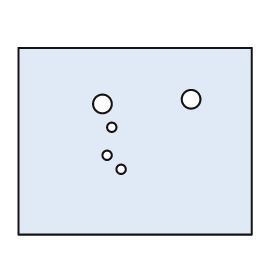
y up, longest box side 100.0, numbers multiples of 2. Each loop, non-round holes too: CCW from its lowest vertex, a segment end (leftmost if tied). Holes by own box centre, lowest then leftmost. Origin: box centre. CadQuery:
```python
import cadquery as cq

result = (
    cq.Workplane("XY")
    .moveTo(-50.0, -40.0)
    .lineTo(50.0, -40.0)
    .lineTo(50.0, 40.0)
    .lineTo(-50.0, 40.0)
    .close()
    .moveTo(-6.0, -12.0)
    .circle(2.0)
    .moveTo(-12.0, -6.0)
    .circle(2.0)
    .moveTo(-10.0, 6.0)
    .circle(2.0)
    .moveTo(-14.0, 16.0)
    .circle(4.0)
    .moveTo(24.0, 18.0)
    .circle(4.0)
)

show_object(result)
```